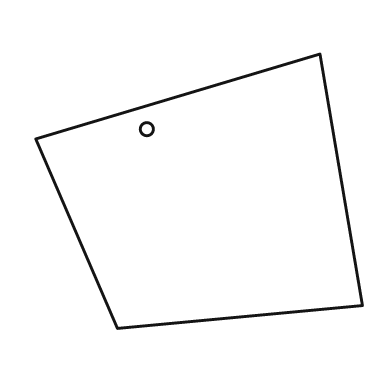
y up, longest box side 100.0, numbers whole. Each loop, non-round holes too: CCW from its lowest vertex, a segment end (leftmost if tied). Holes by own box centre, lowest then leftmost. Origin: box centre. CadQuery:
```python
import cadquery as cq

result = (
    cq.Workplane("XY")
    .moveTo(-25.0, -42.0)
    .lineTo(50.0, -35.0)
    .lineTo(37.0, 42.0)
    .lineTo(-50.0, 16.0)
    .close()
    .moveTo(-16.0, 19.0)
    .circle(2.0)
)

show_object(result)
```